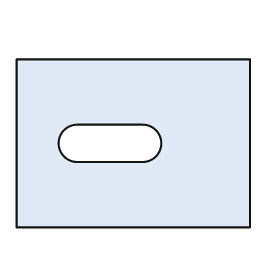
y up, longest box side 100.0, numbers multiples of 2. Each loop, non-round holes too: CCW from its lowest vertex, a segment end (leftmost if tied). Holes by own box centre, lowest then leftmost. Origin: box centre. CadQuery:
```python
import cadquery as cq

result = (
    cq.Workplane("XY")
    .moveTo(-50.0, -36.0)
    .lineTo(50.0, -36.0)
    .lineTo(50.0, 36.0)
    .lineTo(-50.0, 36.0)
    .close()
    .moveTo(-24.0, -8.0)
    .lineTo(4.0, -8.0)
    .threePointArc((12.0, 0.0), (4.0, 8.0))
    .lineTo(-24.0, 8.0)
    .threePointArc((-32.0, 0.0), (-24.0, -8.0))
    .close()
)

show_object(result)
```